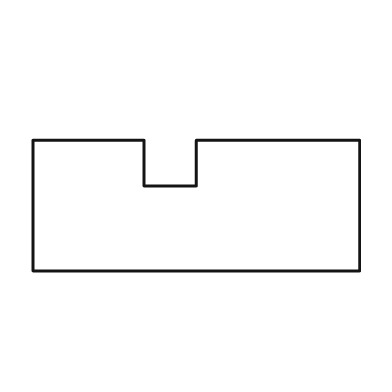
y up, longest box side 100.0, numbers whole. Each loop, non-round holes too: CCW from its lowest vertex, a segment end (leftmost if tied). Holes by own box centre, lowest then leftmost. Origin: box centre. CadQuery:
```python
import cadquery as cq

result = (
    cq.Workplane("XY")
    .moveTo(-50.0, -20.0)
    .lineTo(50.0, -20.0)
    .lineTo(50.0, 20.0)
    .lineTo(0.0, 20.0)
    .lineTo(0.0, 6.0)
    .lineTo(-16.0, 6.0)
    .lineTo(-16.0, 20.0)
    .lineTo(-50.0, 20.0)
    .close()
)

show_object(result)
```